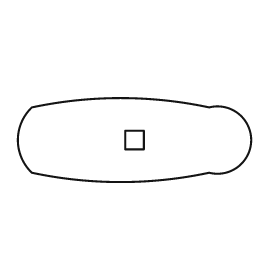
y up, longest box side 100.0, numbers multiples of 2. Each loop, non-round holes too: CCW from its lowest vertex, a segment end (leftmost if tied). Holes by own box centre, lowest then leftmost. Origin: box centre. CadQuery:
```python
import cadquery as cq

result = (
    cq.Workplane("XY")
    .moveTo(-44.0, -14.0)
    .threePointArc((-6.0, -18.0), (32.0, -14.0))
    .threePointArc((50.0, 0.0), (32.0, 14.0))
    .threePointArc((-6.0, 18.0), (-44.0, 14.0))
    .threePointArc((-50.0, 0.0), (-44.0, -14.0))
    .close()
    .moveTo(-4.0, -4.0)
    .lineTo(4.0, -4.0)
    .lineTo(4.0, 4.0)
    .lineTo(-4.0, 4.0)
    .close()
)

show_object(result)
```